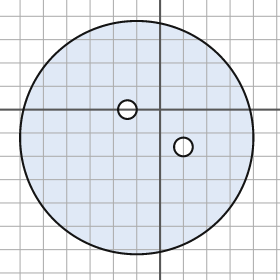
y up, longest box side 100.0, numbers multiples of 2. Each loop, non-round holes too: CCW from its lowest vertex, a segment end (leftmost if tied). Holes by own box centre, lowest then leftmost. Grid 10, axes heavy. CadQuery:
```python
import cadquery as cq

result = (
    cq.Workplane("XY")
    .moveTo(-10.0, -12.0)
    .circle(50.0)
    .moveTo(10.0, -16.0)
    .circle(4.0)
    .moveTo(-14.0, 0.0)
    .circle(4.0)
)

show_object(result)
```